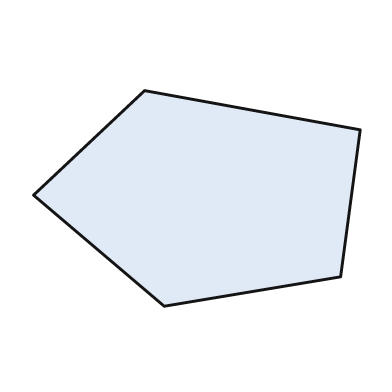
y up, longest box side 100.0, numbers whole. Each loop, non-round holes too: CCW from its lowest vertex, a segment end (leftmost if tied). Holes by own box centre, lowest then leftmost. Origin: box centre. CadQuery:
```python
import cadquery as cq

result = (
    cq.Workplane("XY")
    .moveTo(-10.0, -33.0)
    .lineTo(44.0, -24.0)
    .lineTo(50.0, 21.0)
    .lineTo(-16.0, 33.0)
    .lineTo(-50.0, 1.0)
    .close()
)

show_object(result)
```